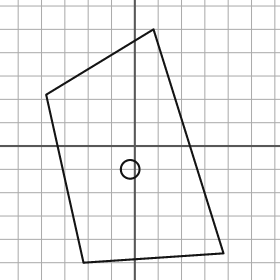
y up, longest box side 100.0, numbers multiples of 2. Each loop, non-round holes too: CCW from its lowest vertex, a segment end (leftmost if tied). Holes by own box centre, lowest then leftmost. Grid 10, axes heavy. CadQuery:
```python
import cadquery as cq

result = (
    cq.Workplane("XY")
    .moveTo(-22.0, -50.0)
    .lineTo(38.0, -46.0)
    .lineTo(8.0, 50.0)
    .lineTo(-38.0, 22.0)
    .close()
    .moveTo(-2.0, -10.0)
    .circle(4.0)
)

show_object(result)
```